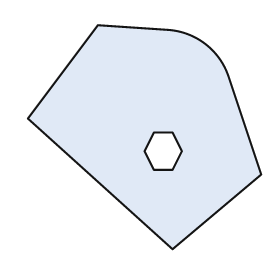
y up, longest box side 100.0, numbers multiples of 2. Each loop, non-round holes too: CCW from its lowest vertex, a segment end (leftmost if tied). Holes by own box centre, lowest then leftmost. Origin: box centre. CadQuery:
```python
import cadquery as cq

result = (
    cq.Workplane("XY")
    .moveTo(12.0, -48.0)
    .lineTo(50.0, -16.0)
    .lineTo(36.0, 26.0)
    .threePointArc((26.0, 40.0), (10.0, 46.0))
    .lineTo(-20.0, 48.0)
    .lineTo(-50.0, 8.0)
    .close()
    .moveTo(4.0, -14.0)
    .lineTo(12.0, -14.0)
    .lineTo(16.0, -6.0)
    .lineTo(12.0, 2.0)
    .lineTo(4.0, 2.0)
    .lineTo(0.0, -6.0)
    .close()
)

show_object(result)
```